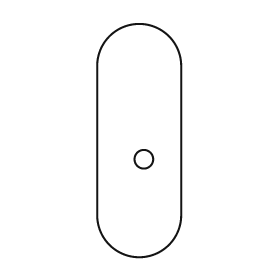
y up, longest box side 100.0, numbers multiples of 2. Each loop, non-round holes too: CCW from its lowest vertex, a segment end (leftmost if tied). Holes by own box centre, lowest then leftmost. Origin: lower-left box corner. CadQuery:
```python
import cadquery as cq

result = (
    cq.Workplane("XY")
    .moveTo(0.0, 18.0)
    .threePointArc((18.0, 0.0), (36.0, 18.0))
    .lineTo(36.0, 82.0)
    .threePointArc((18.0, 100.0), (0.0, 82.0))
    .close()
    .moveTo(20.0, 42.0)
    .circle(4.0)
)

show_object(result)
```